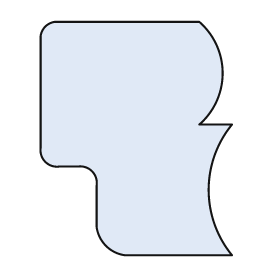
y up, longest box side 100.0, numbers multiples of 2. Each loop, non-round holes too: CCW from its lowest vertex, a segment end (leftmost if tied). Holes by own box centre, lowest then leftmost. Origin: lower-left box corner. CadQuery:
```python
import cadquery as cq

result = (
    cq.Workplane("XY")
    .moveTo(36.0, 0.0)
    .lineTo(82.0, 0.0)
    .threePointArc((72.0, 28.0), (82.0, 56.0))
    .lineTo(68.0, 56.0)
    .threePointArc((78.0, 78.0), (68.0, 100.0))
    .lineTo(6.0, 100.0)
    .threePointArc((2.0, 98.0), (0.0, 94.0))
    .lineTo(0.0, 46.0)
    .threePointArc((2.0, 40.0), (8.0, 38.0))
    .lineTo(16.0, 38.0)
    .threePointArc((22.0, 36.0), (24.0, 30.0))
    .lineTo(24.0, 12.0)
    .threePointArc((28.0, 4.0), (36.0, 0.0))
    .close()
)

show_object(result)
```